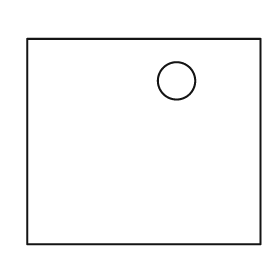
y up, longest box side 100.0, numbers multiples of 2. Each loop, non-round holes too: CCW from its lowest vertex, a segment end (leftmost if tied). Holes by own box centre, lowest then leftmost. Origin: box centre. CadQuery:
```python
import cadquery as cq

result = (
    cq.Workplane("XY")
    .moveTo(-50.0, -44.0)
    .lineTo(50.0, -44.0)
    .lineTo(50.0, 44.0)
    .lineTo(-50.0, 44.0)
    .close()
    .moveTo(14.0, 26.0)
    .circle(8.0)
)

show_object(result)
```